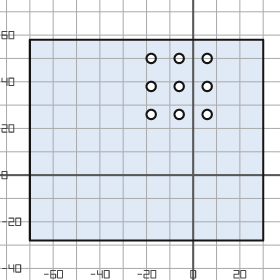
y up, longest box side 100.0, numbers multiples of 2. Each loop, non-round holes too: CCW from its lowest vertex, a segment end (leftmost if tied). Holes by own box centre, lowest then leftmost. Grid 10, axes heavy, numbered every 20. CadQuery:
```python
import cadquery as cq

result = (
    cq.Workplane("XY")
    .moveTo(-70.0, -28.0)
    .lineTo(30.0, -28.0)
    .lineTo(30.0, 58.0)
    .lineTo(-70.0, 58.0)
    .close()
    .moveTo(-18.0, 26.0)
    .circle(2.0)
    .moveTo(-6.0, 26.0)
    .circle(2.0)
    .moveTo(6.0, 26.0)
    .circle(2.0)
    .moveTo(-18.0, 38.0)
    .circle(2.0)
    .moveTo(-6.0, 38.0)
    .circle(2.0)
    .moveTo(6.0, 38.0)
    .circle(2.0)
    .moveTo(-18.0, 50.0)
    .circle(2.0)
    .moveTo(-6.0, 50.0)
    .circle(2.0)
    .moveTo(6.0, 50.0)
    .circle(2.0)
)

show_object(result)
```